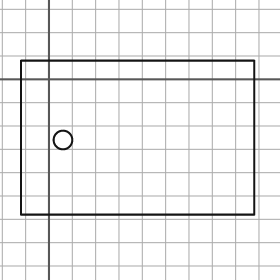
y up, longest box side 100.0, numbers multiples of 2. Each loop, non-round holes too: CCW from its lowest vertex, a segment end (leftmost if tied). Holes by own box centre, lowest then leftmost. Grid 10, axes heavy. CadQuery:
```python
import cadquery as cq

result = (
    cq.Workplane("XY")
    .moveTo(-12.0, -58.0)
    .lineTo(88.0, -58.0)
    .lineTo(88.0, 8.0)
    .lineTo(-12.0, 8.0)
    .close()
    .moveTo(6.0, -26.0)
    .circle(4.0)
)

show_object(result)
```